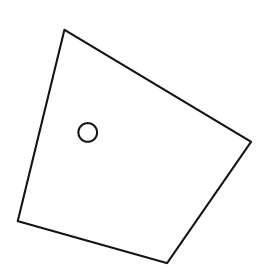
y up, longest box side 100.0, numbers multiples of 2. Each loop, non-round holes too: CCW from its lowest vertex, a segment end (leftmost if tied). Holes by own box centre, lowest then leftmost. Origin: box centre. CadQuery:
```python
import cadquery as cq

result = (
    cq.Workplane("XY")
    .moveTo(14.0, -50.0)
    .lineTo(50.0, 2.0)
    .lineTo(-30.0, 50.0)
    .lineTo(-50.0, -32.0)
    .close()
    .moveTo(-20.0, 6.0)
    .circle(4.0)
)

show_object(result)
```